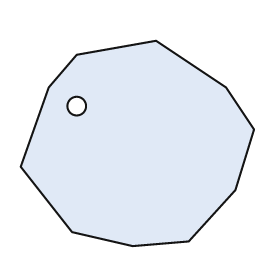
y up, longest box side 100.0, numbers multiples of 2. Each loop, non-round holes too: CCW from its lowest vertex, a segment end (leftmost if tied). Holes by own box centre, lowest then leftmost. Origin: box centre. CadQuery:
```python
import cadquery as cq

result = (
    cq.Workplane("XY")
    .moveTo(-2.0, -44.0)
    .lineTo(22.0, -42.0)
    .lineTo(42.0, -20.0)
    .lineTo(50.0, 6.0)
    .lineTo(38.0, 24.0)
    .lineTo(8.0, 44.0)
    .lineTo(-26.0, 38.0)
    .lineTo(-38.0, 24.0)
    .lineTo(-50.0, -10.0)
    .lineTo(-28.0, -38.0)
    .close()
    .moveTo(-26.0, 16.0)
    .circle(4.0)
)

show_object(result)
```